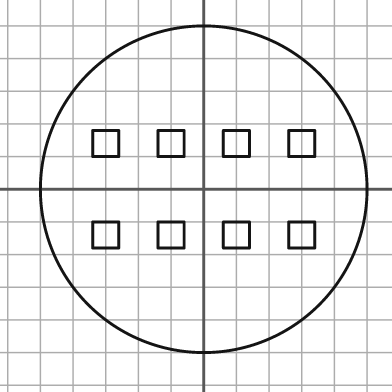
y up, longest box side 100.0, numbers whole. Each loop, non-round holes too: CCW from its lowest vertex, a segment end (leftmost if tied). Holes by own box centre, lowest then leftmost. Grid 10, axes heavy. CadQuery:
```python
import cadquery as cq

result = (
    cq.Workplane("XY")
    .moveTo(0.0, 0.0)
    .circle(50.0)
    .moveTo(-34.0, -18.0)
    .lineTo(-26.0, -18.0)
    .lineTo(-26.0, -10.0)
    .lineTo(-34.0, -10.0)
    .close()
    .moveTo(-14.0, -18.0)
    .lineTo(-6.0, -18.0)
    .lineTo(-6.0, -10.0)
    .lineTo(-14.0, -10.0)
    .close()
    .moveTo(6.0, -18.0)
    .lineTo(14.0, -18.0)
    .lineTo(14.0, -10.0)
    .lineTo(6.0, -10.0)
    .close()
    .moveTo(26.0, -18.0)
    .lineTo(34.0, -18.0)
    .lineTo(34.0, -10.0)
    .lineTo(26.0, -10.0)
    .close()
    .moveTo(-34.0, 10.0)
    .lineTo(-26.0, 10.0)
    .lineTo(-26.0, 18.0)
    .lineTo(-34.0, 18.0)
    .close()
    .moveTo(-14.0, 10.0)
    .lineTo(-6.0, 10.0)
    .lineTo(-6.0, 18.0)
    .lineTo(-14.0, 18.0)
    .close()
    .moveTo(6.0, 10.0)
    .lineTo(14.0, 10.0)
    .lineTo(14.0, 18.0)
    .lineTo(6.0, 18.0)
    .close()
    .moveTo(26.0, 10.0)
    .lineTo(34.0, 10.0)
    .lineTo(34.0, 18.0)
    .lineTo(26.0, 18.0)
    .close()
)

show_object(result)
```